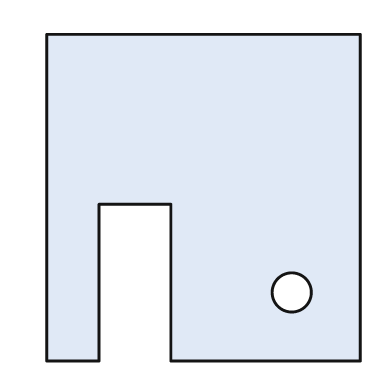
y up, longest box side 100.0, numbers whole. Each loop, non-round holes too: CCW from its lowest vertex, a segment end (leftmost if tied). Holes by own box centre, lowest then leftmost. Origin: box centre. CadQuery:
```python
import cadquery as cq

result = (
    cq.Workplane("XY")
    .moveTo(-48.0, -50.0)
    .lineTo(-32.0, -50.0)
    .lineTo(-32.0, -2.0)
    .lineTo(-10.0, -2.0)
    .lineTo(-10.0, -50.0)
    .lineTo(48.0, -50.0)
    .lineTo(48.0, 50.0)
    .lineTo(-48.0, 50.0)
    .close()
    .moveTo(27.0, -29.0)
    .circle(6.0)
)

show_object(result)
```